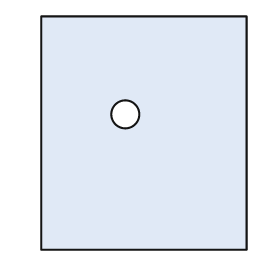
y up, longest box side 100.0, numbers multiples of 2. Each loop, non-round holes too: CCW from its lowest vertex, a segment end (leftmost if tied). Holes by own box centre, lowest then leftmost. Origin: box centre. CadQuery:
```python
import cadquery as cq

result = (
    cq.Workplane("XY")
    .moveTo(-44.0, -50.0)
    .lineTo(44.0, -50.0)
    .lineTo(44.0, 50.0)
    .lineTo(-44.0, 50.0)
    .close()
    .moveTo(-8.0, 8.0)
    .circle(6.0)
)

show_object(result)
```